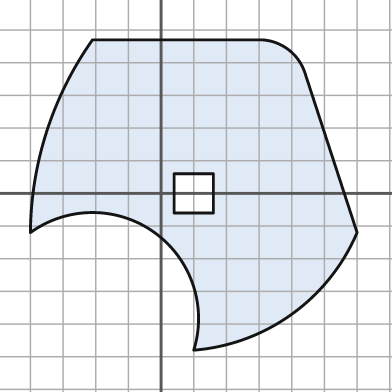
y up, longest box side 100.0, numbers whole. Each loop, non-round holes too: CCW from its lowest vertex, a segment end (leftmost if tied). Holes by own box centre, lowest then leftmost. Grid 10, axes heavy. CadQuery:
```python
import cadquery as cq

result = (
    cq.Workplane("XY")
    .moveTo(10.0, -48.0)
    .threePointArc((40.0, -37.0), (60.0, -12.0))
    .lineTo(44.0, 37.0)
    .threePointArc((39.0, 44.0), (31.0, 47.0))
    .lineTo(-21.0, 47.0)
    .threePointArc((-35.0, 19.0), (-40.0, -12.0))
    .threePointArc((-2.0, -12.0), (10.0, -48.0))
    .close()
    .moveTo(4.0, -6.0)
    .lineTo(16.0, -6.0)
    .lineTo(16.0, 6.0)
    .lineTo(4.0, 6.0)
    .close()
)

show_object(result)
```